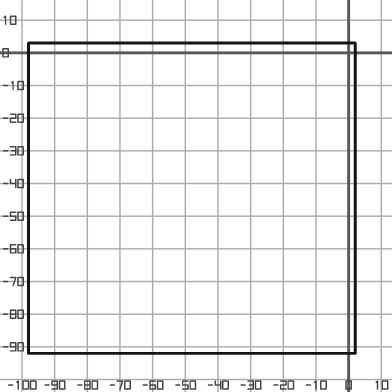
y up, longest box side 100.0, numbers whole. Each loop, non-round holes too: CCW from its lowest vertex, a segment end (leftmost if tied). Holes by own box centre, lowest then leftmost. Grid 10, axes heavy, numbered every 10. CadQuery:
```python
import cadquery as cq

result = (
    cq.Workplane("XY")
    .moveTo(-98.0, -92.0)
    .lineTo(2.0, -92.0)
    .lineTo(2.0, 3.0)
    .lineTo(-98.0, 3.0)
    .close()
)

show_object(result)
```